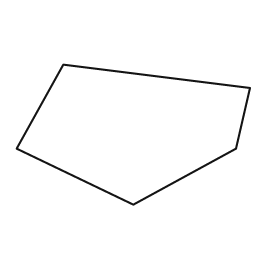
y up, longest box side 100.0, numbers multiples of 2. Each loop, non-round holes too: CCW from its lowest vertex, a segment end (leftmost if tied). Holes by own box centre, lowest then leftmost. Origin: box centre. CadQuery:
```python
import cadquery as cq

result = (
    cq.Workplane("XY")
    .moveTo(0.0, -30.0)
    .lineTo(44.0, -6.0)
    .lineTo(50.0, 20.0)
    .lineTo(-30.0, 30.0)
    .lineTo(-50.0, -6.0)
    .close()
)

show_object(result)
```